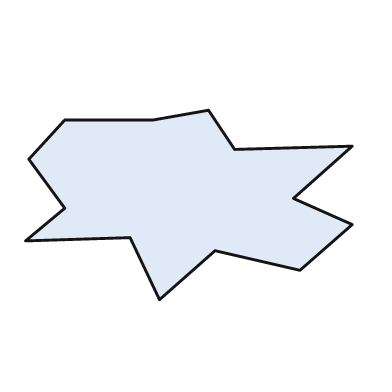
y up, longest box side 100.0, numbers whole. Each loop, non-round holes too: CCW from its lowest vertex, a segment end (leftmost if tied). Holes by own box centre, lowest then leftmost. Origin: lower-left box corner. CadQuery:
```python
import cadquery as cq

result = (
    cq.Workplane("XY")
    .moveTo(41.0, 0.0)
    .lineTo(58.0, 15.0)
    .lineTo(84.0, 9.0)
    .lineTo(100.0, 23.0)
    .lineTo(82.0, 31.0)
    .lineTo(100.0, 47.0)
    .lineTo(64.0, 46.0)
    .lineTo(56.0, 58.0)
    .lineTo(39.0, 55.0)
    .lineTo(12.0, 55.0)
    .lineTo(1.0, 43.0)
    .lineTo(12.0, 28.0)
    .lineTo(0.0, 18.0)
    .lineTo(32.0, 19.0)
    .close()
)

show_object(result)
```